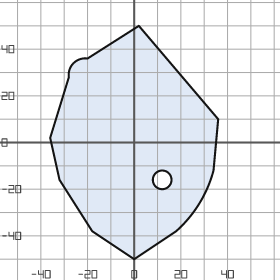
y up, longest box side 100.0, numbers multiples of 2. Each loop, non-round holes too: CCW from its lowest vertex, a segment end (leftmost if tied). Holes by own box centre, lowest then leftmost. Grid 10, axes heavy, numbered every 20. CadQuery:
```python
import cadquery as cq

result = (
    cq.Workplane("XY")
    .moveTo(0.0, -50.0)
    .lineTo(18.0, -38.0)
    .threePointArc((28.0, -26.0), (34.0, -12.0))
    .lineTo(36.0, 10.0)
    .lineTo(2.0, 50.0)
    .lineTo(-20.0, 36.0)
    .threePointArc((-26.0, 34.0), (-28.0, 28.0))
    .lineTo(-36.0, 2.0)
    .lineTo(-32.0, -16.0)
    .lineTo(-18.0, -38.0)
    .close()
    .moveTo(12.0, -16.0)
    .circle(4.0)
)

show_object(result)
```